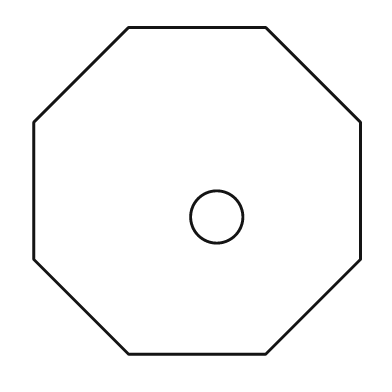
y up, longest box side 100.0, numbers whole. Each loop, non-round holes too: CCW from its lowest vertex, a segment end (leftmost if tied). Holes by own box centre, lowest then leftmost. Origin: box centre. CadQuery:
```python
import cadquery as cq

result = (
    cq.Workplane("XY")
    .moveTo(-21.0, -50.0)
    .lineTo(21.0, -50.0)
    .lineTo(50.0, -21.0)
    .lineTo(50.0, 21.0)
    .lineTo(21.0, 50.0)
    .lineTo(-21.0, 50.0)
    .lineTo(-50.0, 21.0)
    .lineTo(-50.0, -21.0)
    .close()
    .moveTo(6.0, -8.0)
    .circle(8.0)
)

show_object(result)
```